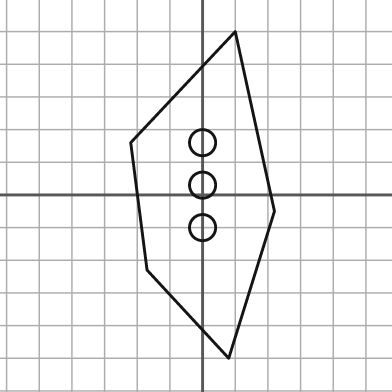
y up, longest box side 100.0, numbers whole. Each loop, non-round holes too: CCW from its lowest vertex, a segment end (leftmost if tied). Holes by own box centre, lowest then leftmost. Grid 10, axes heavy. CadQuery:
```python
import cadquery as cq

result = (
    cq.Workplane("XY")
    .moveTo(8.0, -50.0)
    .lineTo(22.0, -5.0)
    .lineTo(10.0, 50.0)
    .lineTo(-22.0, 16.0)
    .lineTo(-17.0, -23.0)
    .close()
    .moveTo(0.0, -10.0)
    .circle(4.0)
    .moveTo(0.0, 3.0)
    .circle(4.0)
    .moveTo(0.0, 16.0)
    .circle(4.0)
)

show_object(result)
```